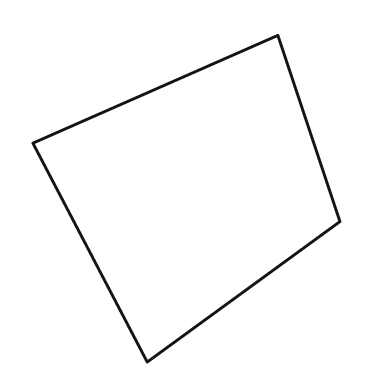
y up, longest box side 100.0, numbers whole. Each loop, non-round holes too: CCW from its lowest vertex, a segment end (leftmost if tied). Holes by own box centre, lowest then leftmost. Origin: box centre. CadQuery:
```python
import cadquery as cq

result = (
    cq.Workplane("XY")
    .moveTo(-12.0, -50.0)
    .lineTo(47.0, -7.0)
    .lineTo(28.0, 50.0)
    .lineTo(-47.0, 17.0)
    .close()
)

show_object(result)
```